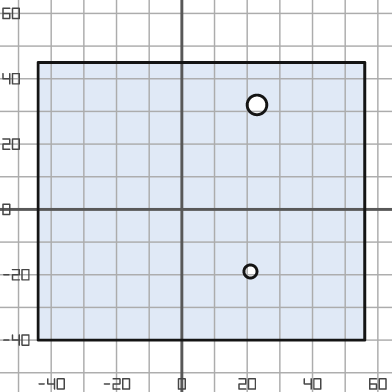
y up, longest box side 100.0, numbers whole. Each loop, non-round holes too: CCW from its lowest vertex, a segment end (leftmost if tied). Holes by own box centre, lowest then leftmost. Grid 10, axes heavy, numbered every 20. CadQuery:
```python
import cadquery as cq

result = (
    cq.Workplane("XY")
    .moveTo(-44.0, -40.0)
    .lineTo(56.0, -40.0)
    .lineTo(56.0, 45.0)
    .lineTo(-44.0, 45.0)
    .close()
    .moveTo(21.0, -19.0)
    .circle(2.0)
    .moveTo(23.0, 32.0)
    .circle(3.0)
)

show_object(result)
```